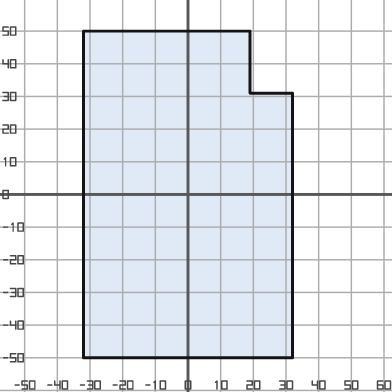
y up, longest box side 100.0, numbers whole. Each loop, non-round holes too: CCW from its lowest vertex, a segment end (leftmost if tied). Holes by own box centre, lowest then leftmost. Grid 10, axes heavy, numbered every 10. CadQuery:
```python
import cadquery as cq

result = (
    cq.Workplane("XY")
    .moveTo(-32.0, -50.0)
    .lineTo(32.0, -50.0)
    .lineTo(32.0, 31.0)
    .lineTo(19.0, 31.0)
    .lineTo(19.0, 50.0)
    .lineTo(-32.0, 50.0)
    .close()
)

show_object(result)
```